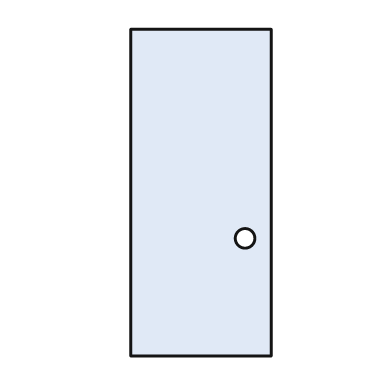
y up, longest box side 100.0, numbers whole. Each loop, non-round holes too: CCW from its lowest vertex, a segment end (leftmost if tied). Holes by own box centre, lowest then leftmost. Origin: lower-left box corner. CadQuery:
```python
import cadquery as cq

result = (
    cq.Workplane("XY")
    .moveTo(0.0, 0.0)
    .lineTo(43.0, 0.0)
    .lineTo(43.0, 100.0)
    .lineTo(0.0, 100.0)
    .close()
    .moveTo(35.0, 36.0)
    .circle(3.0)
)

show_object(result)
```